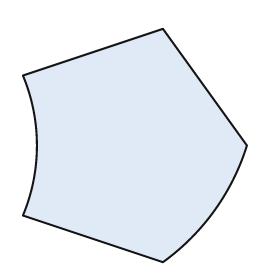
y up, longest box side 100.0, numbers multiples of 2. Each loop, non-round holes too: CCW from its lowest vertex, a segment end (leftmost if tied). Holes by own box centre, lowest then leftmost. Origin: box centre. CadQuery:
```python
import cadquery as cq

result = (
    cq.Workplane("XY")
    .moveTo(12.0, -50.0)
    .threePointArc((34.0, -28.0), (48.0, 0.0))
    .lineTo(12.0, 50.0)
    .lineTo(-48.0, 30.0)
    .threePointArc((-42.0, 0.0), (-48.0, -30.0))
    .close()
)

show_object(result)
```